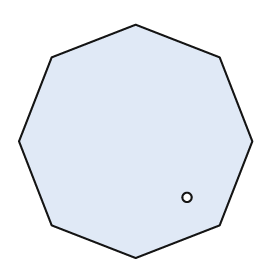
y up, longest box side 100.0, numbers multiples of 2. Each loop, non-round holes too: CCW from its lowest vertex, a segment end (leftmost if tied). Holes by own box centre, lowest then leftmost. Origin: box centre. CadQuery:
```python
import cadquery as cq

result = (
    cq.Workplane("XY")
    .moveTo(0.0, -50.0)
    .lineTo(36.0, -36.0)
    .lineTo(50.0, 0.0)
    .lineTo(36.0, 36.0)
    .lineTo(0.0, 50.0)
    .lineTo(-36.0, 36.0)
    .lineTo(-50.0, 0.0)
    .lineTo(-36.0, -36.0)
    .close()
    .moveTo(22.0, -24.0)
    .circle(2.0)
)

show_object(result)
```